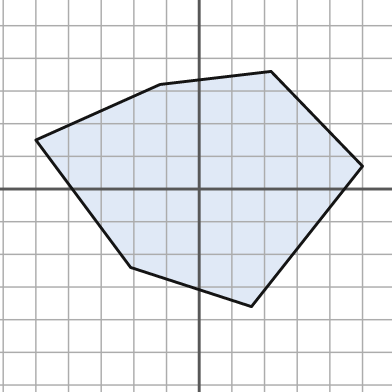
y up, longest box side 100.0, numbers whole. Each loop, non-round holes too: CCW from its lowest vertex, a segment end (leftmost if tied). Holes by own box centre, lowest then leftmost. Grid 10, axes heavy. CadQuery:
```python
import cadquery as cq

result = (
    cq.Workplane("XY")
    .moveTo(16.0, -36.0)
    .lineTo(50.0, 7.0)
    .lineTo(22.0, 36.0)
    .lineTo(-12.0, 32.0)
    .lineTo(-50.0, 15.0)
    .lineTo(-21.0, -24.0)
    .close()
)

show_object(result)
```